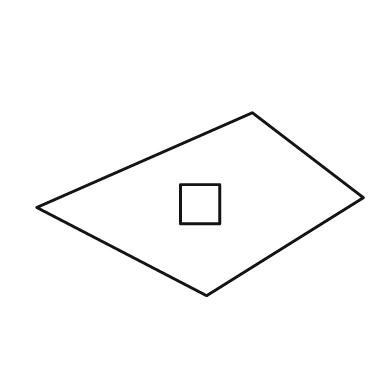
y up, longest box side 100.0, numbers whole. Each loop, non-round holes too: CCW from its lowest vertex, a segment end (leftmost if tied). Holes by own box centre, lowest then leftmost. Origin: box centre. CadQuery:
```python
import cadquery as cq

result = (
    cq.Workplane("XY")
    .moveTo(2.0, -28.0)
    .lineTo(50.0, 2.0)
    .lineTo(16.0, 28.0)
    .lineTo(-50.0, -1.0)
    .close()
    .moveTo(-6.0, -6.0)
    .lineTo(6.0, -6.0)
    .lineTo(6.0, 6.0)
    .lineTo(-6.0, 6.0)
    .close()
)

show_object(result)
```